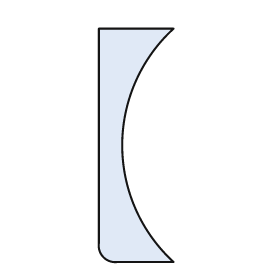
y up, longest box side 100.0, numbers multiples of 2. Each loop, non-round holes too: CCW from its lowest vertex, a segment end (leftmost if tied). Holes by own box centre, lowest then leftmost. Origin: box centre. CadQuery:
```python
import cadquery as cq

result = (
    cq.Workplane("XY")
    .moveTo(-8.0, -50.0)
    .lineTo(16.0, -50.0)
    .threePointArc((-6.0, 0.0), (16.0, 50.0))
    .lineTo(-16.0, 50.0)
    .lineTo(-16.0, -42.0)
    .threePointArc((-14.0, -48.0), (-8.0, -50.0))
    .close()
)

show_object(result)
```